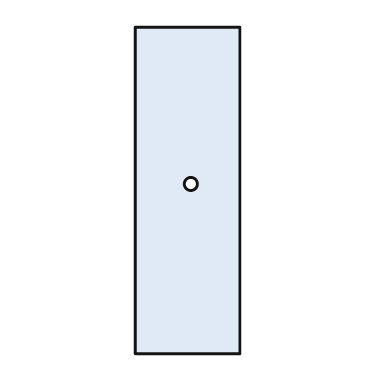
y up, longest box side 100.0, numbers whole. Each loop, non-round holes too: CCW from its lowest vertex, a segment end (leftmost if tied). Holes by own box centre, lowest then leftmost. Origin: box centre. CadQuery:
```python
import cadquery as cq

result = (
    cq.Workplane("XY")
    .moveTo(-16.0, -50.0)
    .lineTo(16.0, -50.0)
    .lineTo(16.0, 50.0)
    .lineTo(-16.0, 50.0)
    .close()
    .moveTo(1.0, 2.0)
    .circle(2.0)
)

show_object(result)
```